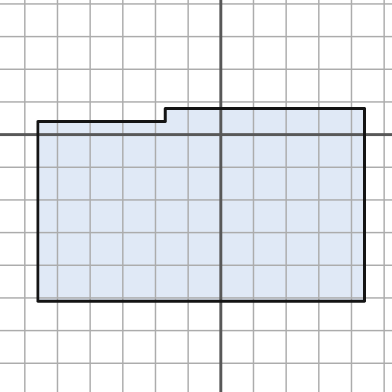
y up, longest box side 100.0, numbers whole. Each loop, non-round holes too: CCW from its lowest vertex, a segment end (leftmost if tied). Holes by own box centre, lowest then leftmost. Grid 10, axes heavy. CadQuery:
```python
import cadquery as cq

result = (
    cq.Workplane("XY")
    .moveTo(-56.0, -51.0)
    .lineTo(44.0, -51.0)
    .lineTo(44.0, 8.0)
    .lineTo(-17.0, 8.0)
    .lineTo(-17.0, 4.0)
    .lineTo(-56.0, 4.0)
    .close()
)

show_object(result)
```